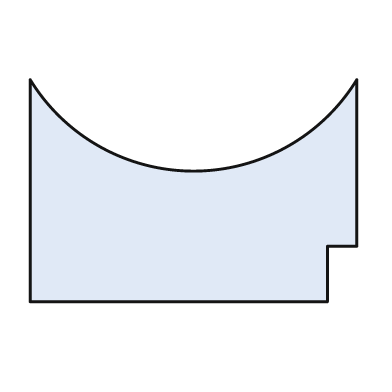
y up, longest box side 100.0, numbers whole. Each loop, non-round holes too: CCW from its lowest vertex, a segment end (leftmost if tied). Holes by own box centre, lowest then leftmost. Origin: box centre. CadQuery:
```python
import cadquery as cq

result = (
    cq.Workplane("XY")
    .moveTo(-50.0, -34.0)
    .lineTo(41.0, -34.0)
    .lineTo(41.0, -17.0)
    .lineTo(50.0, -17.0)
    .lineTo(50.0, 34.0)
    .threePointArc((0.0, 6.0), (-50.0, 34.0))
    .close()
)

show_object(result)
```